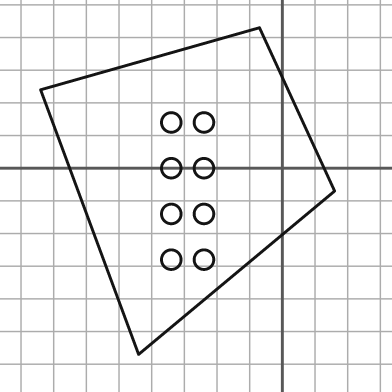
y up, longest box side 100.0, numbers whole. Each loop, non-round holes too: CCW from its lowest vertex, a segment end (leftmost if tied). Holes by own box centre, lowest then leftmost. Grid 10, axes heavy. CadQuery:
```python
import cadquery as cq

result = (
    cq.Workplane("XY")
    .moveTo(-44.0, -57.0)
    .lineTo(16.0, -7.0)
    .lineTo(-7.0, 43.0)
    .lineTo(-74.0, 24.0)
    .close()
    .moveTo(-34.0, -28.0)
    .circle(3.0)
    .moveTo(-24.0, -28.0)
    .circle(3.0)
    .moveTo(-34.0, -14.0)
    .circle(3.0)
    .moveTo(-24.0, -14.0)
    .circle(3.0)
    .moveTo(-34.0, 0.0)
    .circle(3.0)
    .moveTo(-24.0, 0.0)
    .circle(3.0)
    .moveTo(-34.0, 14.0)
    .circle(3.0)
    .moveTo(-24.0, 14.0)
    .circle(3.0)
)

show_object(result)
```